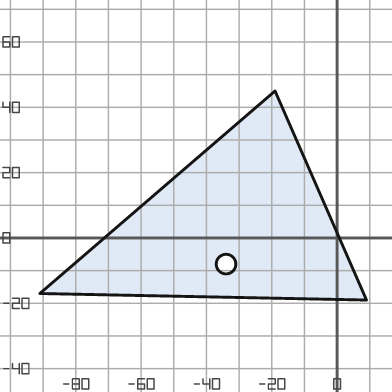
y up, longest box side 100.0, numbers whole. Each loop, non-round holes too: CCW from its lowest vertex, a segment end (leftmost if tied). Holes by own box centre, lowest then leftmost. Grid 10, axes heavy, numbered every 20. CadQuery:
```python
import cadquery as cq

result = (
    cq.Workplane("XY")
    .moveTo(9.0, -19.0)
    .lineTo(-19.0, 45.0)
    .lineTo(-91.0, -17.0)
    .close()
    .moveTo(-34.0, -8.0)
    .circle(3.0)
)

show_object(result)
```